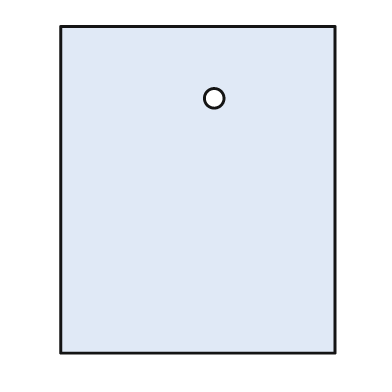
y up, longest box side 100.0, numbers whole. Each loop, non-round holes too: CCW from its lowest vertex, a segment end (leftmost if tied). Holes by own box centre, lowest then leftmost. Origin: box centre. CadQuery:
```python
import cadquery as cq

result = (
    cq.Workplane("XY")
    .moveTo(-42.0, -50.0)
    .lineTo(42.0, -50.0)
    .lineTo(42.0, 50.0)
    .lineTo(-42.0, 50.0)
    .close()
    .moveTo(5.0, 28.0)
    .circle(3.0)
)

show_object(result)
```